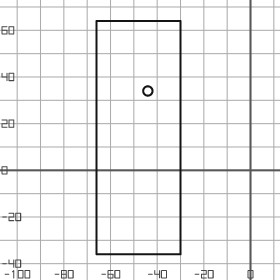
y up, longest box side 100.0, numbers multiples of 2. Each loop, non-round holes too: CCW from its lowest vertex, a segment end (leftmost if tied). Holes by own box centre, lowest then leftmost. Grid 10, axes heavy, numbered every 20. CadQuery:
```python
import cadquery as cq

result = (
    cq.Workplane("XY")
    .moveTo(-66.0, -36.0)
    .lineTo(-30.0, -36.0)
    .lineTo(-30.0, 64.0)
    .lineTo(-66.0, 64.0)
    .close()
    .moveTo(-44.0, 34.0)
    .circle(2.0)
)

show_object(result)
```